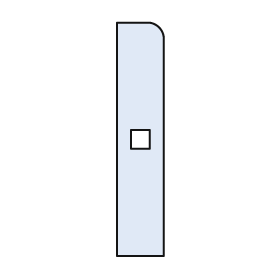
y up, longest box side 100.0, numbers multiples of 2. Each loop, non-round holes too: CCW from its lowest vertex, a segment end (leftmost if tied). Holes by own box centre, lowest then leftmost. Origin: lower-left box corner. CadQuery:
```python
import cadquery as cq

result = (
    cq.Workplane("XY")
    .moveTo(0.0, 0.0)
    .lineTo(20.0, 0.0)
    .lineTo(20.0, 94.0)
    .threePointArc((18.0, 98.0), (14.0, 100.0))
    .lineTo(0.0, 100.0)
    .close()
    .moveTo(6.0, 46.0)
    .lineTo(14.0, 46.0)
    .lineTo(14.0, 54.0)
    .lineTo(6.0, 54.0)
    .close()
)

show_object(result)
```